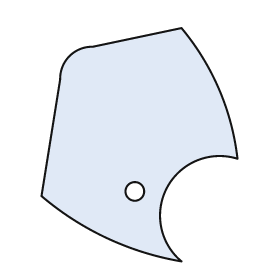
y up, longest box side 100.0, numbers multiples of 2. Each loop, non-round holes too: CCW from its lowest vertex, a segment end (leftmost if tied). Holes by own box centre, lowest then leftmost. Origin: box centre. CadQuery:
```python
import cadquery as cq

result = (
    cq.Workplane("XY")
    .moveTo(18.0, -50.0)
    .threePointArc((12.0, -18.0), (42.0, -6.0))
    .threePointArc((34.0, 24.0), (18.0, 50.0))
    .lineTo(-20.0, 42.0)
    .threePointArc((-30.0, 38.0), (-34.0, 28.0))
    .lineTo(-42.0, -22.0)
    .threePointArc((-14.0, -40.0), (18.0, -50.0))
    .close()
    .moveTo(-2.0, -20.0)
    .circle(4.0)
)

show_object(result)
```